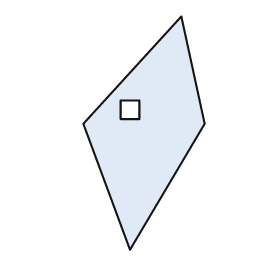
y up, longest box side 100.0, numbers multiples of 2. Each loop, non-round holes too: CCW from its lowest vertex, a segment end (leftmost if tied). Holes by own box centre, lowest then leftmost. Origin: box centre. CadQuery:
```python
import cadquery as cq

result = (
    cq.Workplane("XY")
    .moveTo(-6.0, -50.0)
    .lineTo(26.0, 4.0)
    .lineTo(16.0, 50.0)
    .lineTo(-26.0, 4.0)
    .close()
    .moveTo(-10.0, 6.0)
    .lineTo(-2.0, 6.0)
    .lineTo(-2.0, 14.0)
    .lineTo(-10.0, 14.0)
    .close()
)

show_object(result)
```